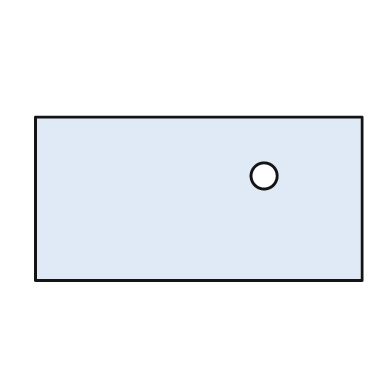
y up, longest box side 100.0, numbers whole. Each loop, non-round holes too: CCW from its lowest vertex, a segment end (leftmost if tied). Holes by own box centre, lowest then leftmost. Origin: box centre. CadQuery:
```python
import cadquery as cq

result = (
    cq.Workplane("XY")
    .moveTo(-50.0, -25.0)
    .lineTo(50.0, -25.0)
    .lineTo(50.0, 25.0)
    .lineTo(-50.0, 25.0)
    .close()
    .moveTo(20.0, 7.0)
    .circle(4.0)
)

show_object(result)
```